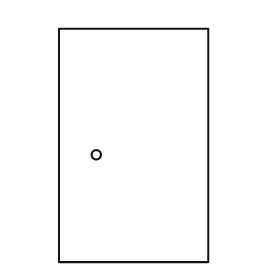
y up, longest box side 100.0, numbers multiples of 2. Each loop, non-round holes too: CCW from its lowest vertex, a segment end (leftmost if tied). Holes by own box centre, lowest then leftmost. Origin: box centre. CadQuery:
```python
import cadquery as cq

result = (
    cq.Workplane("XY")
    .moveTo(-32.0, -50.0)
    .lineTo(32.0, -50.0)
    .lineTo(32.0, 50.0)
    .lineTo(-32.0, 50.0)
    .close()
    .moveTo(-16.0, -4.0)
    .circle(2.0)
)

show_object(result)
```